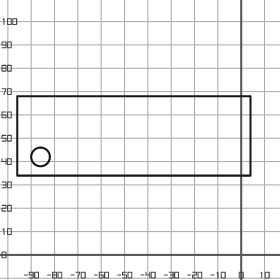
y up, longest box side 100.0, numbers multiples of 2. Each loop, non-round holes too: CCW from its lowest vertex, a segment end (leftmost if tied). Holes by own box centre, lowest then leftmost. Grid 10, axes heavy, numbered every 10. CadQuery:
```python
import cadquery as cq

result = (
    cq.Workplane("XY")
    .moveTo(-96.0, 34.0)
    .lineTo(4.0, 34.0)
    .lineTo(4.0, 68.0)
    .lineTo(-96.0, 68.0)
    .close()
    .moveTo(-86.0, 42.0)
    .circle(4.0)
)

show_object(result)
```